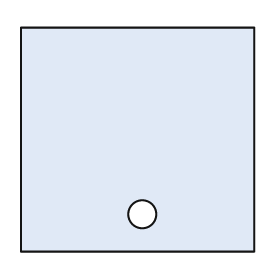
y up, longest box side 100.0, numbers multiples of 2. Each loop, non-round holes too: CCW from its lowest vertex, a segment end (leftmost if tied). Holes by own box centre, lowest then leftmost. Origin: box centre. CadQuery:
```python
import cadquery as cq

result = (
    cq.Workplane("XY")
    .moveTo(-50.0, -48.0)
    .lineTo(50.0, -48.0)
    .lineTo(50.0, 48.0)
    .lineTo(-50.0, 48.0)
    .close()
    .moveTo(2.0, -32.0)
    .circle(6.0)
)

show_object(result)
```